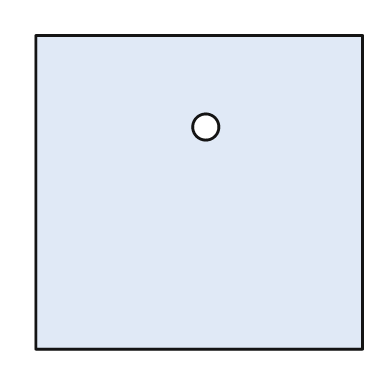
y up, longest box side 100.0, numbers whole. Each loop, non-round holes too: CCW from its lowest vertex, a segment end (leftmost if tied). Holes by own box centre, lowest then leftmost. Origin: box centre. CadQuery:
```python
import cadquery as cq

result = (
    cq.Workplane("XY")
    .moveTo(-50.0, -48.0)
    .lineTo(50.0, -48.0)
    .lineTo(50.0, 48.0)
    .lineTo(-50.0, 48.0)
    .close()
    .moveTo(2.0, 20.0)
    .circle(4.0)
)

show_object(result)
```